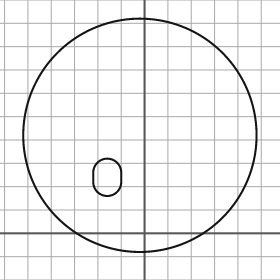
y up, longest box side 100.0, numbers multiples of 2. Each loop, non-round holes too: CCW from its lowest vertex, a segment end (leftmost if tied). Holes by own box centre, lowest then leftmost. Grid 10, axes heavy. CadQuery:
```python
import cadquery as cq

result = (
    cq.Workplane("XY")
    .moveTo(-2.0, 42.0)
    .circle(50.0)
    .moveTo(-22.0, 22.0)
    .threePointArc((-16.0, 16.0), (-10.0, 22.0))
    .lineTo(-10.0, 26.0)
    .threePointArc((-16.0, 32.0), (-22.0, 26.0))
    .close()
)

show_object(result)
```